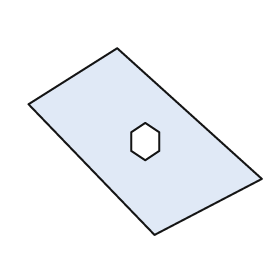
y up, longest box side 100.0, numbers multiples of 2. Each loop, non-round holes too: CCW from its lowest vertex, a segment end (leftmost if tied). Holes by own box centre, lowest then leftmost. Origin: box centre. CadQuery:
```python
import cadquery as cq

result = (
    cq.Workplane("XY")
    .moveTo(4.0, -40.0)
    .lineTo(50.0, -16.0)
    .lineTo(-12.0, 40.0)
    .lineTo(-50.0, 16.0)
    .close()
    .moveTo(0.0, -8.0)
    .lineTo(6.0, -4.0)
    .lineTo(6.0, 4.0)
    .lineTo(0.0, 8.0)
    .lineTo(-6.0, 4.0)
    .lineTo(-6.0, -4.0)
    .close()
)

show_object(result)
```